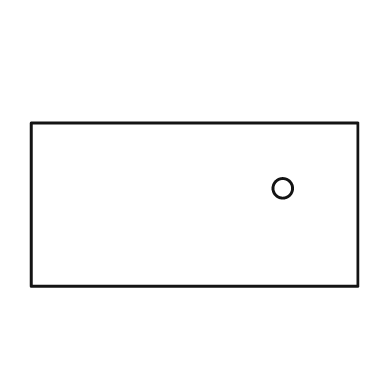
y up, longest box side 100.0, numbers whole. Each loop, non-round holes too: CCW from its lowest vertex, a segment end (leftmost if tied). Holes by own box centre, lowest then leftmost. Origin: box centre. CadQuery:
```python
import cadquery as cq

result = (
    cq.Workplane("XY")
    .moveTo(-50.0, -25.0)
    .lineTo(50.0, -25.0)
    .lineTo(50.0, 25.0)
    .lineTo(-50.0, 25.0)
    .close()
    .moveTo(27.0, 5.0)
    .circle(3.0)
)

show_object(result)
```